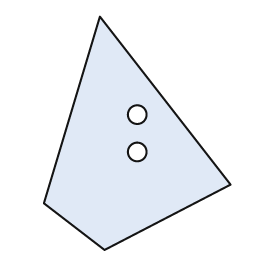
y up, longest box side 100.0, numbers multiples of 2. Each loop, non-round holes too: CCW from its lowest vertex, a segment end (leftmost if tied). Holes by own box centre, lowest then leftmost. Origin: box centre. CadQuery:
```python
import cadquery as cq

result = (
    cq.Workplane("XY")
    .moveTo(-14.0, -50.0)
    .lineTo(40.0, -22.0)
    .lineTo(-16.0, 50.0)
    .lineTo(-40.0, -30.0)
    .close()
    .moveTo(0.0, -8.0)
    .circle(4.0)
    .moveTo(0.0, 8.0)
    .circle(4.0)
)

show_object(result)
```